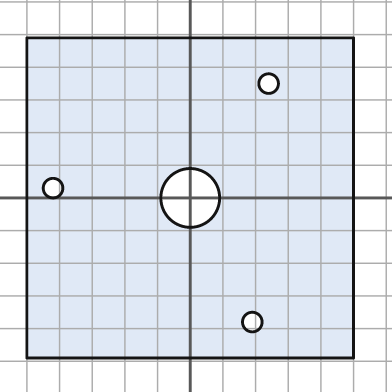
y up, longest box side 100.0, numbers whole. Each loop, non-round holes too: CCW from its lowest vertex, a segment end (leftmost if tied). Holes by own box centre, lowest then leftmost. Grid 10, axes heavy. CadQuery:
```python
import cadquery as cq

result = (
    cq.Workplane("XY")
    .moveTo(-50.0, -49.0)
    .lineTo(50.0, -49.0)
    .lineTo(50.0, 49.0)
    .lineTo(-50.0, 49.0)
    .close()
    .moveTo(19.0, -38.0)
    .circle(3.0)
    .moveTo(0.0, 0.0)
    .circle(9.0)
    .moveTo(-42.0, 3.0)
    .circle(3.0)
    .moveTo(24.0, 35.0)
    .circle(3.0)
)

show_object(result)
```